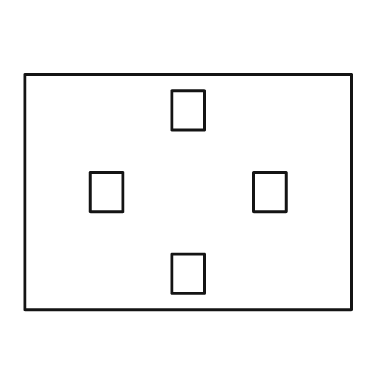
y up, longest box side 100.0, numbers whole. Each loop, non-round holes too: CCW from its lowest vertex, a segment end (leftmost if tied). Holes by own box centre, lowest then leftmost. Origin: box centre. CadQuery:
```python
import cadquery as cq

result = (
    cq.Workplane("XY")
    .moveTo(-50.0, -36.0)
    .lineTo(50.0, -36.0)
    .lineTo(50.0, 36.0)
    .lineTo(-50.0, 36.0)
    .close()
    .moveTo(-5.0, -31.0)
    .lineTo(5.0, -31.0)
    .lineTo(5.0, -19.0)
    .lineTo(-5.0, -19.0)
    .close()
    .moveTo(-30.0, -6.0)
    .lineTo(-20.0, -6.0)
    .lineTo(-20.0, 6.0)
    .lineTo(-30.0, 6.0)
    .close()
    .moveTo(20.0, -6.0)
    .lineTo(30.0, -6.0)
    .lineTo(30.0, 6.0)
    .lineTo(20.0, 6.0)
    .close()
    .moveTo(-5.0, 19.0)
    .lineTo(5.0, 19.0)
    .lineTo(5.0, 31.0)
    .lineTo(-5.0, 31.0)
    .close()
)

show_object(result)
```